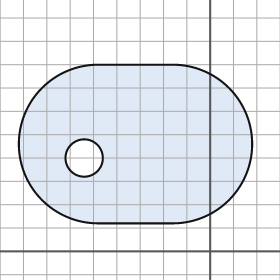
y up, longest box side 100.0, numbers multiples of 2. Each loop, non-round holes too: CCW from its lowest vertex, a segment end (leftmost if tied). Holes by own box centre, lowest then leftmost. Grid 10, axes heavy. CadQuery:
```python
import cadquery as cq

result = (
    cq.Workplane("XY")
    .moveTo(-48.0, 12.0)
    .lineTo(-16.0, 12.0)
    .threePointArc((18.0, 46.0), (-16.0, 80.0))
    .lineTo(-48.0, 80.0)
    .threePointArc((-82.0, 46.0), (-48.0, 12.0))
    .close()
    .moveTo(-54.0, 40.0)
    .circle(8.0)
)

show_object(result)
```